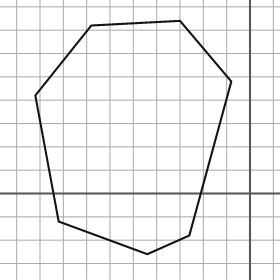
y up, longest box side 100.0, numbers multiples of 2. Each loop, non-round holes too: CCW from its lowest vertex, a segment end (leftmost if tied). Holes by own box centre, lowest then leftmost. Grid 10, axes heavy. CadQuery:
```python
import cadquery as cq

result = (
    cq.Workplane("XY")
    .moveTo(-44.0, -26.0)
    .lineTo(-26.0, -18.0)
    .lineTo(-8.0, 48.0)
    .lineTo(-30.0, 74.0)
    .lineTo(-68.0, 72.0)
    .lineTo(-92.0, 42.0)
    .lineTo(-82.0, -12.0)
    .close()
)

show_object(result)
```